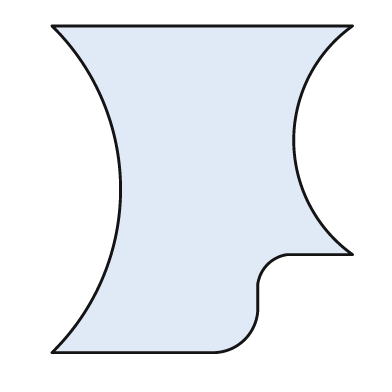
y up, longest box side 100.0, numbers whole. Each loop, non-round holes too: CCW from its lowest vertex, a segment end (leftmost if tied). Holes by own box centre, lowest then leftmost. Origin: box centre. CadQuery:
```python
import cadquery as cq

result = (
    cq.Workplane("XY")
    .moveTo(-46.0, -50.0)
    .lineTo(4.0, -50.0)
    .threePointArc((13.0, -46.0), (17.0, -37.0))
    .lineTo(17.0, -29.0)
    .threePointArc((20.0, -23.0), (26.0, -20.0))
    .lineTo(46.0, -20.0)
    .threePointArc((28.0, 15.0), (46.0, 50.0))
    .lineTo(-46.0, 50.0)
    .threePointArc((-25.0, 0.0), (-46.0, -50.0))
    .close()
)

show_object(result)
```